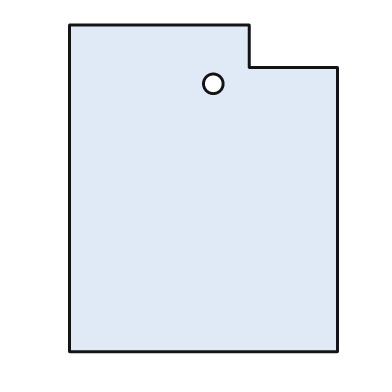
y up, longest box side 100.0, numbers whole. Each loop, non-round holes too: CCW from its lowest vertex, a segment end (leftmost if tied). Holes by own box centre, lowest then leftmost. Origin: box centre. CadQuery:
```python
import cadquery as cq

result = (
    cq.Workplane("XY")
    .moveTo(-41.0, -50.0)
    .lineTo(41.0, -50.0)
    .lineTo(41.0, 37.0)
    .lineTo(14.0, 37.0)
    .lineTo(14.0, 50.0)
    .lineTo(-41.0, 50.0)
    .close()
    .moveTo(3.0, 32.0)
    .circle(3.0)
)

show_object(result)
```